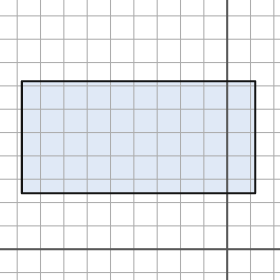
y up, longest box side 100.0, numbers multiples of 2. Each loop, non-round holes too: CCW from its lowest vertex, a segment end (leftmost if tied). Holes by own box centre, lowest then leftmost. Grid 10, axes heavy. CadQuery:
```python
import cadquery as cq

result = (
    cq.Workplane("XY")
    .moveTo(-88.0, 24.0)
    .lineTo(12.0, 24.0)
    .lineTo(12.0, 72.0)
    .lineTo(-88.0, 72.0)
    .close()
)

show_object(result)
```